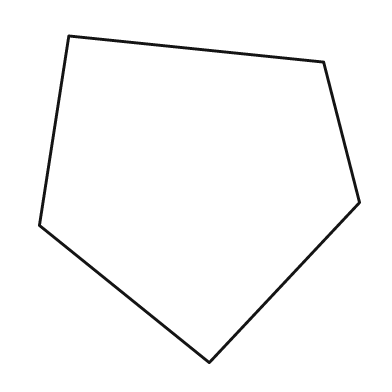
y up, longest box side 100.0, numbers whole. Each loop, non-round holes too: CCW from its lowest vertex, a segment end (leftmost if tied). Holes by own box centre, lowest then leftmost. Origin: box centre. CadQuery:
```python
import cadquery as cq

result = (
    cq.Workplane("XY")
    .moveTo(3.0, -50.0)
    .lineTo(49.0, -1.0)
    .lineTo(38.0, 42.0)
    .lineTo(-40.0, 50.0)
    .lineTo(-49.0, -8.0)
    .close()
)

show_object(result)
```